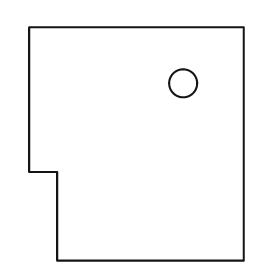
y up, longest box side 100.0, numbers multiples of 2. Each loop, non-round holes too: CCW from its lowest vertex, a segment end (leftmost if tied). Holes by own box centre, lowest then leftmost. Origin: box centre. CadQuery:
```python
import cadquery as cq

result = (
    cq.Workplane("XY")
    .moveTo(-34.0, -50.0)
    .lineTo(46.0, -50.0)
    .lineTo(46.0, 50.0)
    .lineTo(-46.0, 50.0)
    .lineTo(-46.0, -12.0)
    .lineTo(-34.0, -12.0)
    .close()
    .moveTo(20.0, 26.0)
    .circle(6.0)
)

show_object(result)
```